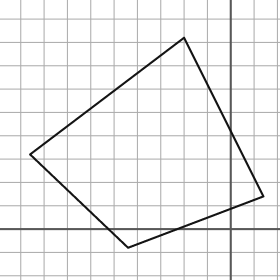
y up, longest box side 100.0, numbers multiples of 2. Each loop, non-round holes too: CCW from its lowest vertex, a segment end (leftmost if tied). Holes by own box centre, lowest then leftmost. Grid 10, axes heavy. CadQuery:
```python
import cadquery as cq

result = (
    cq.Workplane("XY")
    .moveTo(-44.0, -8.0)
    .lineTo(14.0, 14.0)
    .lineTo(-20.0, 82.0)
    .lineTo(-86.0, 32.0)
    .close()
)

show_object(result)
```